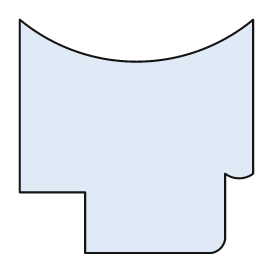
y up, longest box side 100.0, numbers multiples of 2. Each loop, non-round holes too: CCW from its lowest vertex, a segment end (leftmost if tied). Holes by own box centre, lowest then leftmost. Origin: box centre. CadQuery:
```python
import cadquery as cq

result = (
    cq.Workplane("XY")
    .moveTo(-22.0, -50.0)
    .lineTo(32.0, -50.0)
    .threePointArc((36.0, -48.0), (38.0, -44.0))
    .lineTo(38.0, -16.0)
    .threePointArc((44.0, -18.0), (50.0, -16.0))
    .lineTo(50.0, 50.0)
    .threePointArc((0.0, 32.0), (-50.0, 50.0))
    .lineTo(-50.0, -24.0)
    .lineTo(-22.0, -24.0)
    .close()
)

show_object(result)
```